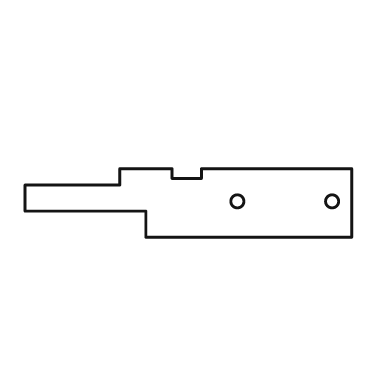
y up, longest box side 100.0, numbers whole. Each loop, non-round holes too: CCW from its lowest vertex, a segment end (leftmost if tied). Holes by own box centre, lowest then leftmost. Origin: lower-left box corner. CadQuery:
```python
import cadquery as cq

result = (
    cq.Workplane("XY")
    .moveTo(37.0, 0.0)
    .lineTo(100.0, 0.0)
    .lineTo(100.0, 21.0)
    .lineTo(54.0, 21.0)
    .lineTo(54.0, 18.0)
    .lineTo(45.0, 18.0)
    .lineTo(45.0, 21.0)
    .lineTo(29.0, 21.0)
    .lineTo(29.0, 16.0)
    .lineTo(0.0, 16.0)
    .lineTo(0.0, 8.0)
    .lineTo(37.0, 8.0)
    .close()
    .moveTo(65.0, 11.0)
    .circle(2.0)
    .moveTo(94.0, 11.0)
    .circle(2.0)
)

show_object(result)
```